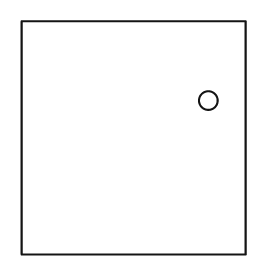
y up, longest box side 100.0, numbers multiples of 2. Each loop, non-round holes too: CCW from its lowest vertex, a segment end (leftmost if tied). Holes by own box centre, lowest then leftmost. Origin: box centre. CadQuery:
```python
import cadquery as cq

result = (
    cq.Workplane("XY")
    .moveTo(-48.0, -50.0)
    .lineTo(48.0, -50.0)
    .lineTo(48.0, 50.0)
    .lineTo(-48.0, 50.0)
    .close()
    .moveTo(32.0, 16.0)
    .circle(4.0)
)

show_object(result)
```